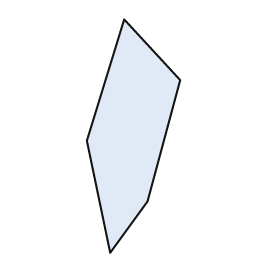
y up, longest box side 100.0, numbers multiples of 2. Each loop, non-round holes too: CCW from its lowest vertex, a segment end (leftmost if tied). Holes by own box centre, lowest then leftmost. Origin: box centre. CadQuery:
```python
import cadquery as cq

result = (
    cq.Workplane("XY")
    .moveTo(-10.0, -50.0)
    .lineTo(6.0, -28.0)
    .lineTo(20.0, 24.0)
    .lineTo(-4.0, 50.0)
    .lineTo(-20.0, -2.0)
    .close()
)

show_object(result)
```